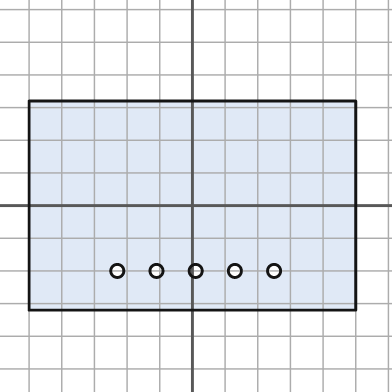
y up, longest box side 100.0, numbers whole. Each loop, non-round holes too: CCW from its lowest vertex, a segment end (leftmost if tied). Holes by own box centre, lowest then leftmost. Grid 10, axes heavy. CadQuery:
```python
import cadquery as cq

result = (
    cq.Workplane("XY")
    .moveTo(-50.0, -32.0)
    .lineTo(50.0, -32.0)
    .lineTo(50.0, 32.0)
    .lineTo(-50.0, 32.0)
    .close()
    .moveTo(-23.0, -20.0)
    .circle(2.0)
    .moveTo(-11.0, -20.0)
    .circle(2.0)
    .moveTo(1.0, -20.0)
    .circle(2.0)
    .moveTo(13.0, -20.0)
    .circle(2.0)
    .moveTo(25.0, -20.0)
    .circle(2.0)
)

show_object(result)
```